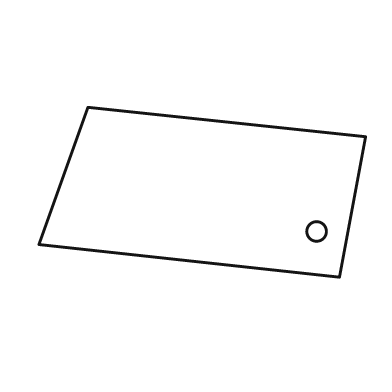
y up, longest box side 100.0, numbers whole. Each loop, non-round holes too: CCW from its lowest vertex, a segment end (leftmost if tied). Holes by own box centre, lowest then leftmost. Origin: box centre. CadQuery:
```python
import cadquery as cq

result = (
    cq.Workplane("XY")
    .moveTo(42.0, -26.0)
    .lineTo(50.0, 17.0)
    .lineTo(-35.0, 26.0)
    .lineTo(-50.0, -16.0)
    .close()
    .moveTo(35.0, -12.0)
    .circle(3.0)
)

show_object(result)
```